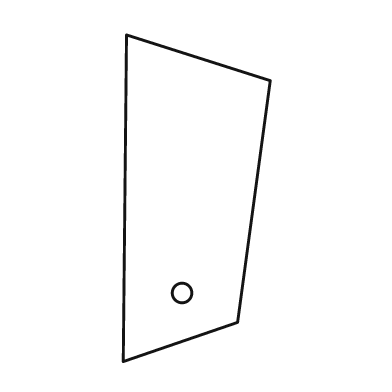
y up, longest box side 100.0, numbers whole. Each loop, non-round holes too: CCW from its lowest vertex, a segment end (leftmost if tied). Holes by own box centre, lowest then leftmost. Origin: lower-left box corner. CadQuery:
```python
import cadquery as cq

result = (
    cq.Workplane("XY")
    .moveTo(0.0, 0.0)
    .lineTo(35.0, 12.0)
    .lineTo(45.0, 86.0)
    .lineTo(1.0, 100.0)
    .close()
    .moveTo(18.0, 21.0)
    .circle(3.0)
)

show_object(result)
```